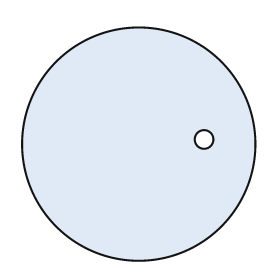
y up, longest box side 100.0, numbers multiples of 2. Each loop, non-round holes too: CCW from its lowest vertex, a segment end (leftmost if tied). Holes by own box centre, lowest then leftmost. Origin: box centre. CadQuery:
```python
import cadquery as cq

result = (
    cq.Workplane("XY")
    .moveTo(0.0, 0.0)
    .circle(50.0)
    .moveTo(28.0, 2.0)
    .circle(4.0)
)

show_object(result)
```